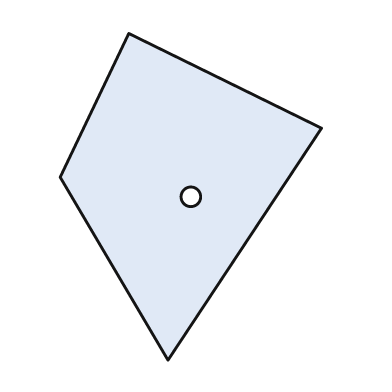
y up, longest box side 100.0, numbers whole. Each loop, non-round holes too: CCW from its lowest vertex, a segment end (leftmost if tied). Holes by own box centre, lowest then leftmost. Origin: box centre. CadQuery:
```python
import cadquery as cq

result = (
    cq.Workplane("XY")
    .moveTo(-7.0, -50.0)
    .lineTo(40.0, 21.0)
    .lineTo(-19.0, 50.0)
    .lineTo(-40.0, 6.0)
    .close()
    .moveTo(0.0, 0.0)
    .circle(3.0)
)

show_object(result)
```